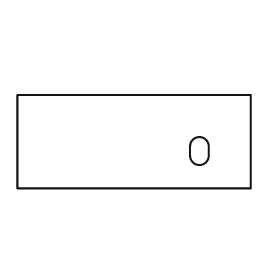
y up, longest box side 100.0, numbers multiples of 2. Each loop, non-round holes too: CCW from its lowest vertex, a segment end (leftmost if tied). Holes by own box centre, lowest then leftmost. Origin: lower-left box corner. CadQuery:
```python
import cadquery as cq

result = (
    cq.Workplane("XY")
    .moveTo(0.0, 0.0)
    .lineTo(100.0, 0.0)
    .lineTo(100.0, 40.0)
    .lineTo(0.0, 40.0)
    .close()
    .moveTo(74.0, 14.0)
    .threePointArc((78.0, 10.0), (82.0, 14.0))
    .lineTo(82.0, 18.0)
    .threePointArc((78.0, 22.0), (74.0, 18.0))
    .close()
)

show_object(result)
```